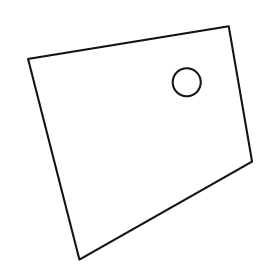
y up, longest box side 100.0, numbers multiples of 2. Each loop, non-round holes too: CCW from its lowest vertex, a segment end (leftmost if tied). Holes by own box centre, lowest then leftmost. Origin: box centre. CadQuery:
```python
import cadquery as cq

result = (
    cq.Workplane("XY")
    .moveTo(-26.0, -50.0)
    .lineTo(48.0, -8.0)
    .lineTo(38.0, 50.0)
    .lineTo(-48.0, 36.0)
    .close()
    .moveTo(20.0, 26.0)
    .circle(6.0)
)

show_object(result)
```